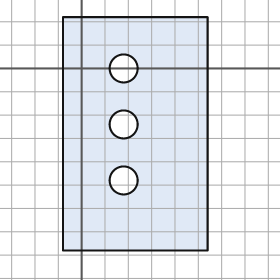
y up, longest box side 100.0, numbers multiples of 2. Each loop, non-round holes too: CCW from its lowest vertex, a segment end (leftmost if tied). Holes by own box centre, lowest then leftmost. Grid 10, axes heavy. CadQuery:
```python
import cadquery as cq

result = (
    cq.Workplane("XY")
    .moveTo(-8.0, -78.0)
    .lineTo(54.0, -78.0)
    .lineTo(54.0, 22.0)
    .lineTo(-8.0, 22.0)
    .close()
    .moveTo(18.0, -48.0)
    .circle(6.0)
    .moveTo(18.0, -24.0)
    .circle(6.0)
    .moveTo(18.0, 0.0)
    .circle(6.0)
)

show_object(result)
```